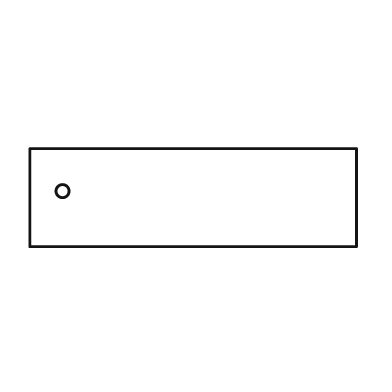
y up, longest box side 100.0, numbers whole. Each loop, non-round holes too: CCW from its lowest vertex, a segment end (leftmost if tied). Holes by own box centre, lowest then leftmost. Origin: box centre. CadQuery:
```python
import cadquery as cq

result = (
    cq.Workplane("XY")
    .moveTo(-50.0, -15.0)
    .lineTo(50.0, -15.0)
    .lineTo(50.0, 15.0)
    .lineTo(-50.0, 15.0)
    .close()
    .moveTo(-40.0, 2.0)
    .circle(2.0)
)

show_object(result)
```